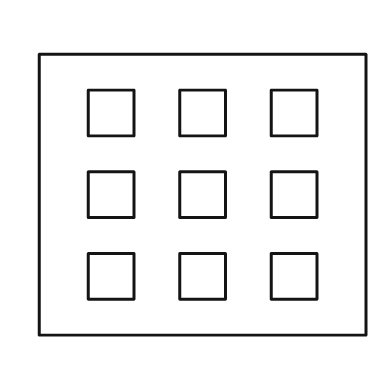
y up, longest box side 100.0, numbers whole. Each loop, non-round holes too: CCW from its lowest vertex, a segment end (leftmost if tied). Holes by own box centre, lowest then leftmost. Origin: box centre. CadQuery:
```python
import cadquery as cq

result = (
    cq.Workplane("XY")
    .moveTo(-50.0, -43.0)
    .lineTo(50.0, -43.0)
    .lineTo(50.0, 43.0)
    .lineTo(-50.0, 43.0)
    .close()
    .moveTo(-35.0, -32.0)
    .lineTo(-21.0, -32.0)
    .lineTo(-21.0, -18.0)
    .lineTo(-35.0, -18.0)
    .close()
    .moveTo(-7.0, -32.0)
    .lineTo(7.0, -32.0)
    .lineTo(7.0, -18.0)
    .lineTo(-7.0, -18.0)
    .close()
    .moveTo(21.0, -32.0)
    .lineTo(35.0, -32.0)
    .lineTo(35.0, -18.0)
    .lineTo(21.0, -18.0)
    .close()
    .moveTo(-35.0, -7.0)
    .lineTo(-21.0, -7.0)
    .lineTo(-21.0, 7.0)
    .lineTo(-35.0, 7.0)
    .close()
    .moveTo(-7.0, -7.0)
    .lineTo(7.0, -7.0)
    .lineTo(7.0, 7.0)
    .lineTo(-7.0, 7.0)
    .close()
    .moveTo(21.0, -7.0)
    .lineTo(35.0, -7.0)
    .lineTo(35.0, 7.0)
    .lineTo(21.0, 7.0)
    .close()
    .moveTo(-35.0, 18.0)
    .lineTo(-21.0, 18.0)
    .lineTo(-21.0, 32.0)
    .lineTo(-35.0, 32.0)
    .close()
    .moveTo(-7.0, 18.0)
    .lineTo(7.0, 18.0)
    .lineTo(7.0, 32.0)
    .lineTo(-7.0, 32.0)
    .close()
    .moveTo(21.0, 18.0)
    .lineTo(35.0, 18.0)
    .lineTo(35.0, 32.0)
    .lineTo(21.0, 32.0)
    .close()
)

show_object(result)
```